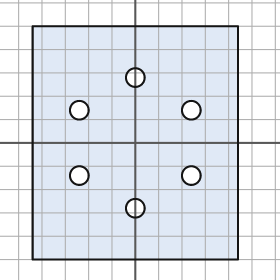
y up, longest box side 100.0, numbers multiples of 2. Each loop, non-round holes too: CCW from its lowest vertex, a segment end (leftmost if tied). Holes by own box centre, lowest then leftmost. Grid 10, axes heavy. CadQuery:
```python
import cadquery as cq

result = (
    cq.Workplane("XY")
    .moveTo(-44.0, -50.0)
    .lineTo(44.0, -50.0)
    .lineTo(44.0, 50.0)
    .lineTo(-44.0, 50.0)
    .close()
    .moveTo(0.0, -28.0)
    .circle(4.0)
    .moveTo(-24.0, -14.0)
    .circle(4.0)
    .moveTo(24.0, -14.0)
    .circle(4.0)
    .moveTo(-24.0, 14.0)
    .circle(4.0)
    .moveTo(24.0, 14.0)
    .circle(4.0)
    .moveTo(0.0, 28.0)
    .circle(4.0)
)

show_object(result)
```